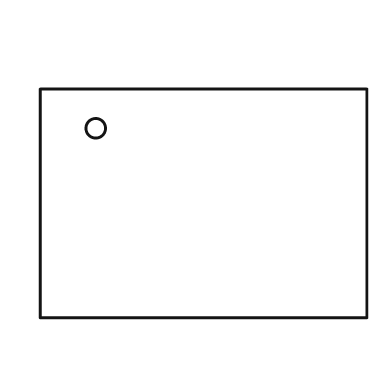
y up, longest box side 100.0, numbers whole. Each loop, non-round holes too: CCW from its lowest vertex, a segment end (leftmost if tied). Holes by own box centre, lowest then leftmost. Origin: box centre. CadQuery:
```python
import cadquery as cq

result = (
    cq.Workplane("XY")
    .moveTo(-50.0, -35.0)
    .lineTo(50.0, -35.0)
    .lineTo(50.0, 35.0)
    .lineTo(-50.0, 35.0)
    .close()
    .moveTo(-33.0, 23.0)
    .circle(3.0)
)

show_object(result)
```